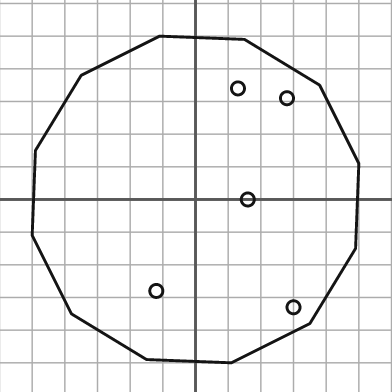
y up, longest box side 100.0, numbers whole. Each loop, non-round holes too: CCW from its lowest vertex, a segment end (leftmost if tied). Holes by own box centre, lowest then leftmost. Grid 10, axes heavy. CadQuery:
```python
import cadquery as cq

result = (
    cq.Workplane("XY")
    .moveTo(11.0, -50.0)
    .lineTo(35.0, -38.0)
    .lineTo(49.0, -15.0)
    .lineTo(50.0, 11.0)
    .lineTo(38.0, 35.0)
    .lineTo(15.0, 49.0)
    .lineTo(-11.0, 50.0)
    .lineTo(-35.0, 38.0)
    .lineTo(-49.0, 15.0)
    .lineTo(-50.0, -11.0)
    .lineTo(-38.0, -35.0)
    .lineTo(-15.0, -49.0)
    .close()
    .moveTo(30.0, -33.0)
    .circle(2.0)
    .moveTo(-12.0, -28.0)
    .circle(2.0)
    .moveTo(16.0, 0.0)
    .circle(2.0)
    .moveTo(28.0, 31.0)
    .circle(2.0)
    .moveTo(13.0, 34.0)
    .circle(2.0)
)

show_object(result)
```